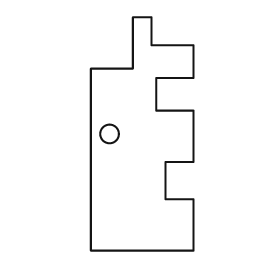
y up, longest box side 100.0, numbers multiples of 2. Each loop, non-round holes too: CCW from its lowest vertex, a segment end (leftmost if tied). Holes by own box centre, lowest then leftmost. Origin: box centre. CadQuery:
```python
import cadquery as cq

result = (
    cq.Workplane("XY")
    .moveTo(-22.0, -50.0)
    .lineTo(22.0, -50.0)
    .lineTo(22.0, -28.0)
    .lineTo(10.0, -28.0)
    .lineTo(10.0, -12.0)
    .lineTo(22.0, -12.0)
    .lineTo(22.0, 10.0)
    .lineTo(6.0, 10.0)
    .lineTo(6.0, 24.0)
    .lineTo(22.0, 24.0)
    .lineTo(22.0, 38.0)
    .lineTo(4.0, 38.0)
    .lineTo(4.0, 50.0)
    .lineTo(-4.0, 50.0)
    .lineTo(-4.0, 28.0)
    .lineTo(-22.0, 28.0)
    .close()
    .moveTo(-14.0, 0.0)
    .circle(4.0)
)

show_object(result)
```